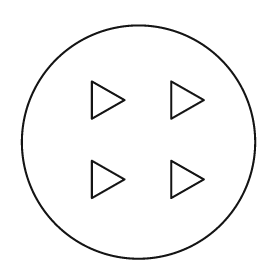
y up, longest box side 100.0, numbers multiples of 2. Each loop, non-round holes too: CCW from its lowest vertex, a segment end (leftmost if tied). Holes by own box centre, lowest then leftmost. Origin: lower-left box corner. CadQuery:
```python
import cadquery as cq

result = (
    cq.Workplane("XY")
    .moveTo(50.0, 50.0)
    .circle(50.0)
    .moveTo(30.0, 26.0)
    .lineTo(44.0, 34.0)
    .lineTo(30.0, 42.0)
    .close()
    .moveTo(64.0, 26.0)
    .lineTo(78.0, 34.0)
    .lineTo(64.0, 42.0)
    .close()
    .moveTo(30.0, 60.0)
    .lineTo(44.0, 68.0)
    .lineTo(30.0, 76.0)
    .close()
    .moveTo(64.0, 60.0)
    .lineTo(78.0, 68.0)
    .lineTo(64.0, 76.0)
    .close()
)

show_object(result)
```